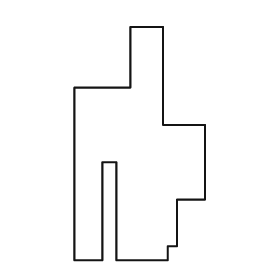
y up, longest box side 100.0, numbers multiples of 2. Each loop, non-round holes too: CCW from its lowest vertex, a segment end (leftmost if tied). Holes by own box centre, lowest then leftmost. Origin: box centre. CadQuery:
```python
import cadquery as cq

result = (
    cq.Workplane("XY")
    .moveTo(-28.0, -50.0)
    .lineTo(-16.0, -50.0)
    .lineTo(-16.0, -8.0)
    .lineTo(-10.0, -8.0)
    .lineTo(-10.0, -50.0)
    .lineTo(12.0, -50.0)
    .lineTo(12.0, -44.0)
    .lineTo(16.0, -44.0)
    .lineTo(16.0, -24.0)
    .lineTo(28.0, -24.0)
    .lineTo(28.0, 8.0)
    .lineTo(10.0, 8.0)
    .lineTo(10.0, 50.0)
    .lineTo(-4.0, 50.0)
    .lineTo(-4.0, 24.0)
    .lineTo(-28.0, 24.0)
    .close()
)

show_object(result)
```